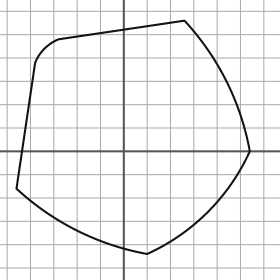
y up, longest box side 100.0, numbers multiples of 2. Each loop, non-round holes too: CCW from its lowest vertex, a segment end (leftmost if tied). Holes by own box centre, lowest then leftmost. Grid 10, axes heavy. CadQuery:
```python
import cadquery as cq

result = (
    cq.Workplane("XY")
    .moveTo(10.0, -44.0)
    .threePointArc((36.0, -26.0), (54.0, 0.0))
    .threePointArc((44.0, 30.0), (26.0, 56.0))
    .lineTo(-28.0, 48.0)
    .threePointArc((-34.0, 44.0), (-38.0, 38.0))
    .lineTo(-46.0, -16.0)
    .threePointArc((-20.0, -34.0), (10.0, -44.0))
    .close()
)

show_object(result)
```